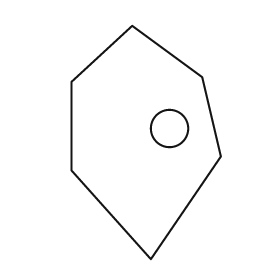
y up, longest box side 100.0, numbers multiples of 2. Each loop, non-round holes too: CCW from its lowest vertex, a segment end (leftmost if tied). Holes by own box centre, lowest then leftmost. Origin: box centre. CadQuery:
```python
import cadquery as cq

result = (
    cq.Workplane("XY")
    .moveTo(2.0, -50.0)
    .lineTo(32.0, -6.0)
    .lineTo(24.0, 28.0)
    .lineTo(-6.0, 50.0)
    .lineTo(-32.0, 26.0)
    .lineTo(-32.0, -12.0)
    .close()
    .moveTo(10.0, 6.0)
    .circle(8.0)
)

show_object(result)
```